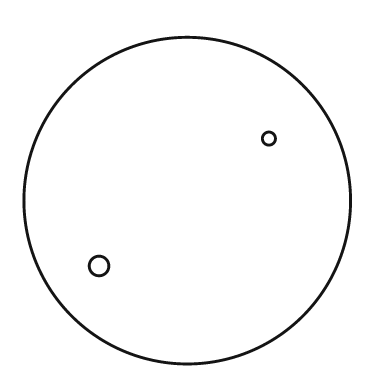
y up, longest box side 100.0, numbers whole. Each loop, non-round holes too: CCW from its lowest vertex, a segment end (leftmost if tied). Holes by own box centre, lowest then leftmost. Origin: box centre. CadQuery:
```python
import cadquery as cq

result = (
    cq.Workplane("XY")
    .moveTo(0.0, 0.0)
    .circle(50.0)
    .moveTo(-27.0, -20.0)
    .circle(3.0)
    .moveTo(25.0, 19.0)
    .circle(2.0)
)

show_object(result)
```